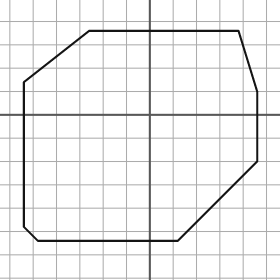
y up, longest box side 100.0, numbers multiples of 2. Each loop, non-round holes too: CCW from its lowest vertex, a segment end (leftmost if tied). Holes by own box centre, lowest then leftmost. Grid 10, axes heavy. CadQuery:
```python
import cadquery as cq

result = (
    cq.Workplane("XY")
    .moveTo(-48.0, -54.0)
    .lineTo(12.0, -54.0)
    .lineTo(46.0, -20.0)
    .lineTo(46.0, 10.0)
    .lineTo(38.0, 36.0)
    .lineTo(-26.0, 36.0)
    .lineTo(-54.0, 14.0)
    .lineTo(-54.0, -48.0)
    .close()
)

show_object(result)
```